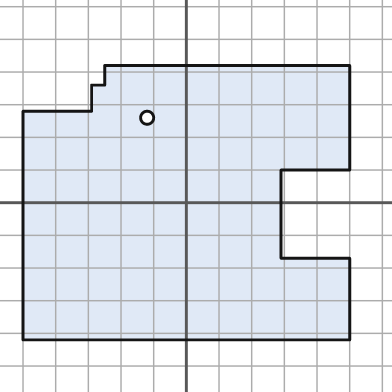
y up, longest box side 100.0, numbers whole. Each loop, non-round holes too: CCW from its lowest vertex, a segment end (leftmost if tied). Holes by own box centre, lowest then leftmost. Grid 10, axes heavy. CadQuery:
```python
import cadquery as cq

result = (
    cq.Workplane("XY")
    .moveTo(-50.0, -42.0)
    .lineTo(50.0, -42.0)
    .lineTo(50.0, -17.0)
    .lineTo(29.0, -17.0)
    .lineTo(29.0, 10.0)
    .lineTo(50.0, 10.0)
    .lineTo(50.0, 42.0)
    .lineTo(-25.0, 42.0)
    .lineTo(-25.0, 36.0)
    .lineTo(-29.0, 36.0)
    .lineTo(-29.0, 28.0)
    .lineTo(-50.0, 28.0)
    .close()
    .moveTo(-12.0, 26.0)
    .circle(2.0)
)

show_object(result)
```